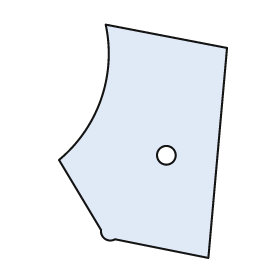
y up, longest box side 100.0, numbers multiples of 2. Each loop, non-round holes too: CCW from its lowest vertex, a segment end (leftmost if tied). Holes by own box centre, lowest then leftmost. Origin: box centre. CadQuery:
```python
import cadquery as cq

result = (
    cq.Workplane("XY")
    .moveTo(28.0, -50.0)
    .lineTo(36.0, 40.0)
    .lineTo(-16.0, 50.0)
    .threePointArc((-18.0, 18.0), (-36.0, -8.0))
    .lineTo(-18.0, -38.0)
    .threePointArc((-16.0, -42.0), (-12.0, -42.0))
    .close()
    .moveTo(10.0, -6.0)
    .circle(4.0)
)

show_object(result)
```